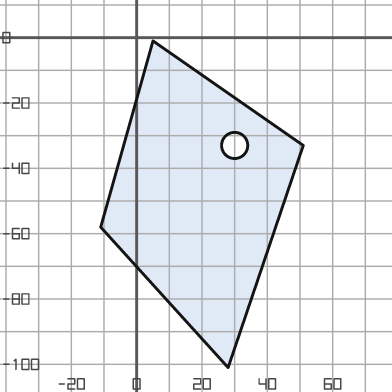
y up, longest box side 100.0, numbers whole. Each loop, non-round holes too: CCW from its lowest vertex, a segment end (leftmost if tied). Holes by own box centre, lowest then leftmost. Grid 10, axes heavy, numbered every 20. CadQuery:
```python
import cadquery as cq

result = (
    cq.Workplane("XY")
    .moveTo(28.0, -101.0)
    .lineTo(51.0, -33.0)
    .lineTo(5.0, -1.0)
    .lineTo(-11.0, -58.0)
    .close()
    .moveTo(30.0, -33.0)
    .circle(4.0)
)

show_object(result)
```